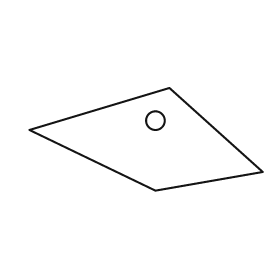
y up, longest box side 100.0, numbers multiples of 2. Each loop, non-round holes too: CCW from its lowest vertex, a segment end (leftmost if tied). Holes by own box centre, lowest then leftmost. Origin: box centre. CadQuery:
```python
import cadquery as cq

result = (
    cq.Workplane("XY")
    .moveTo(4.0, -22.0)
    .lineTo(50.0, -14.0)
    .lineTo(10.0, 22.0)
    .lineTo(-50.0, 4.0)
    .close()
    .moveTo(4.0, 8.0)
    .circle(4.0)
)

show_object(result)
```